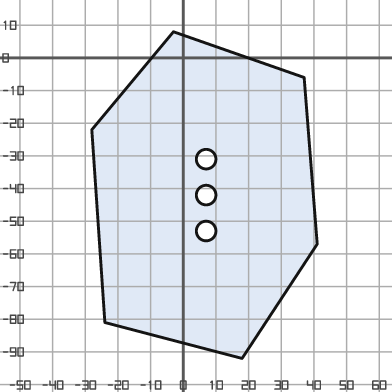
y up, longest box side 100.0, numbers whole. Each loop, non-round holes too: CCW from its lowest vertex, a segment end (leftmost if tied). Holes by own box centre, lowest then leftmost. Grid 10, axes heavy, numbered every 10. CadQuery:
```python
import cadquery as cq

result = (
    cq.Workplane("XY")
    .moveTo(18.0, -92.0)
    .lineTo(41.0, -57.0)
    .lineTo(37.0, -6.0)
    .lineTo(-3.0, 8.0)
    .lineTo(-28.0, -22.0)
    .lineTo(-24.0, -81.0)
    .close()
    .moveTo(7.0, -53.0)
    .circle(3.0)
    .moveTo(7.0, -42.0)
    .circle(3.0)
    .moveTo(7.0, -31.0)
    .circle(3.0)
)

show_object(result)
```